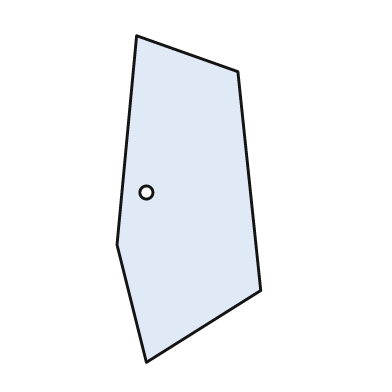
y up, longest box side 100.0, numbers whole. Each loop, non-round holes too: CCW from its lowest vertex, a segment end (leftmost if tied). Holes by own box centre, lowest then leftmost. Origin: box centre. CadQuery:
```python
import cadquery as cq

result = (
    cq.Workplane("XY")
    .moveTo(-13.0, -50.0)
    .lineTo(22.0, -28.0)
    .lineTo(15.0, 39.0)
    .lineTo(-16.0, 50.0)
    .lineTo(-22.0, -14.0)
    .close()
    .moveTo(-13.0, 2.0)
    .circle(2.0)
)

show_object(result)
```